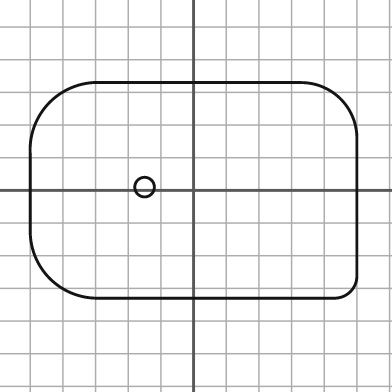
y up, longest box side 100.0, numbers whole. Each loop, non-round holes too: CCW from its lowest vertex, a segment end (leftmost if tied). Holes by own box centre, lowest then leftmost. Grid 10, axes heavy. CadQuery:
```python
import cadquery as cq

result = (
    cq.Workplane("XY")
    .moveTo(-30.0, -33.0)
    .lineTo(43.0, -33.0)
    .threePointArc((48.0, -31.0), (50.0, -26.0))
    .lineTo(50.0, 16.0)
    .threePointArc((45.0, 28.0), (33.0, 33.0))
    .lineTo(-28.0, 33.0)
    .threePointArc((-44.0, 27.0), (-50.0, 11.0))
    .lineTo(-50.0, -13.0)
    .threePointArc((-44.0, -27.0), (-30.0, -33.0))
    .close()
    .moveTo(-15.0, 1.0)
    .circle(3.0)
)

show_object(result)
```